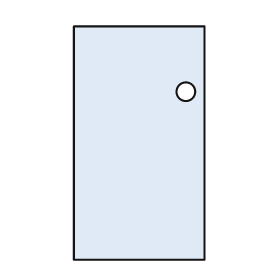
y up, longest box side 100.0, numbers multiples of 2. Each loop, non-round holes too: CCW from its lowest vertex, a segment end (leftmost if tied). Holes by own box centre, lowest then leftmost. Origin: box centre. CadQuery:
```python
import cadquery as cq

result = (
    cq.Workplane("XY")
    .moveTo(-28.0, -50.0)
    .lineTo(28.0, -50.0)
    .lineTo(28.0, 50.0)
    .lineTo(-28.0, 50.0)
    .close()
    .moveTo(20.0, 22.0)
    .circle(4.0)
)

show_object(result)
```